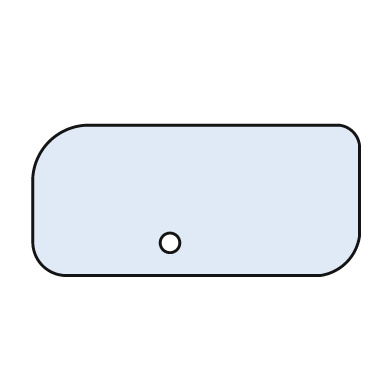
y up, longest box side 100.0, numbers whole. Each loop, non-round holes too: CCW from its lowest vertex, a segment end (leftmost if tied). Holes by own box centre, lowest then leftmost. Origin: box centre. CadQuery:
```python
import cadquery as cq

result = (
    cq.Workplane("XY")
    .moveTo(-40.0, -23.0)
    .lineTo(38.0, -23.0)
    .threePointArc((46.0, -19.0), (50.0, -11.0))
    .lineTo(50.0, 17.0)
    .threePointArc((48.0, 21.0), (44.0, 23.0))
    .lineTo(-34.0, 23.0)
    .threePointArc((-45.0, 18.0), (-50.0, 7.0))
    .lineTo(-50.0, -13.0)
    .threePointArc((-47.0, -20.0), (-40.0, -23.0))
    .close()
    .moveTo(-8.0, -13.0)
    .circle(3.0)
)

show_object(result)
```